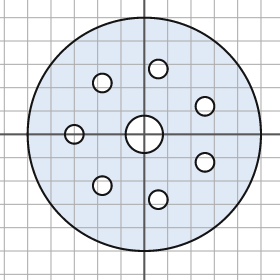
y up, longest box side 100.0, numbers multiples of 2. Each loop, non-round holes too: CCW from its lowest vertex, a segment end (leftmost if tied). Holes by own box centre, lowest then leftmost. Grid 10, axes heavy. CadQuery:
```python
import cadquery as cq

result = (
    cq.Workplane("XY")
    .moveTo(0.0, 0.0)
    .circle(50.0)
    .moveTo(6.0, -28.0)
    .circle(4.0)
    .moveTo(-18.0, -22.0)
    .circle(4.0)
    .moveTo(26.0, -12.0)
    .circle(4.0)
    .moveTo(-30.0, 0.0)
    .circle(4.0)
    .moveTo(0.0, 0.0)
    .circle(8.0)
    .moveTo(26.0, 12.0)
    .circle(4.0)
    .moveTo(-18.0, 22.0)
    .circle(4.0)
    .moveTo(6.0, 28.0)
    .circle(4.0)
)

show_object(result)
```